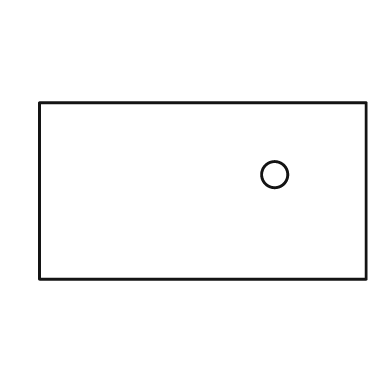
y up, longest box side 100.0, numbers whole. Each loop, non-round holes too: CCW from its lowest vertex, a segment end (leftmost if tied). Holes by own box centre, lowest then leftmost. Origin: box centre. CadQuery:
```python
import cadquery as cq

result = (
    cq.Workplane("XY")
    .moveTo(-50.0, -27.0)
    .lineTo(50.0, -27.0)
    .lineTo(50.0, 27.0)
    .lineTo(-50.0, 27.0)
    .close()
    .moveTo(22.0, 5.0)
    .circle(4.0)
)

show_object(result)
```